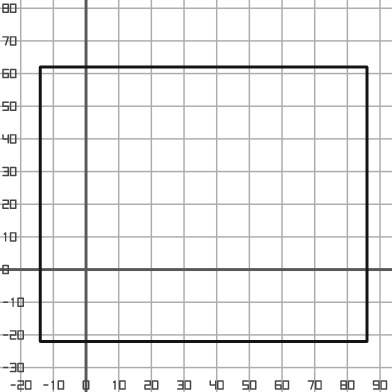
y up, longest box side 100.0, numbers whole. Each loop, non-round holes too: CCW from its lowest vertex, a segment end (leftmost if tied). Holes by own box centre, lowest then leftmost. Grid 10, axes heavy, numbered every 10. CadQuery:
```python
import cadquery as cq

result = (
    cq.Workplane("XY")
    .moveTo(-14.0, -22.0)
    .lineTo(86.0, -22.0)
    .lineTo(86.0, 62.0)
    .lineTo(-14.0, 62.0)
    .close()
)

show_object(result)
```